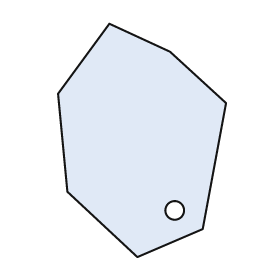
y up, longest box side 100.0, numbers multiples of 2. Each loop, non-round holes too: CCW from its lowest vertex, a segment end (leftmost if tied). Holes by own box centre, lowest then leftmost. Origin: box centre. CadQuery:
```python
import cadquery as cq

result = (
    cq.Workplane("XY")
    .moveTo(-2.0, -50.0)
    .lineTo(26.0, -38.0)
    .lineTo(36.0, 16.0)
    .lineTo(12.0, 38.0)
    .lineTo(-14.0, 50.0)
    .lineTo(-36.0, 20.0)
    .lineTo(-32.0, -22.0)
    .close()
    .moveTo(14.0, -30.0)
    .circle(4.0)
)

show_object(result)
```